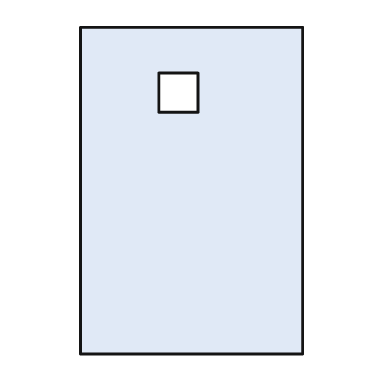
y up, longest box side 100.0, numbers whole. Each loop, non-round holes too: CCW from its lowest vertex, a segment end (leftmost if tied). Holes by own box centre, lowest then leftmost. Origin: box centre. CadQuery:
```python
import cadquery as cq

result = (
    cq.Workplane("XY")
    .moveTo(-34.0, -50.0)
    .lineTo(34.0, -50.0)
    .lineTo(34.0, 50.0)
    .lineTo(-34.0, 50.0)
    .close()
    .moveTo(-10.0, 24.0)
    .lineTo(2.0, 24.0)
    .lineTo(2.0, 36.0)
    .lineTo(-10.0, 36.0)
    .close()
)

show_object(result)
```